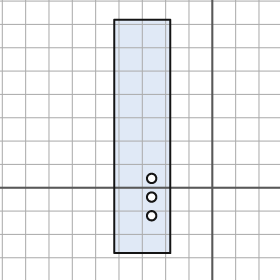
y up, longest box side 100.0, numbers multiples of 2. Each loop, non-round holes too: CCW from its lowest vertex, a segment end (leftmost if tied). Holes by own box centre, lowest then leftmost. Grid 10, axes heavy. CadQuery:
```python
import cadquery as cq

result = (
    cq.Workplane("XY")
    .moveTo(-42.0, -28.0)
    .lineTo(-18.0, -28.0)
    .lineTo(-18.0, 72.0)
    .lineTo(-42.0, 72.0)
    .close()
    .moveTo(-26.0, -12.0)
    .circle(2.0)
    .moveTo(-26.0, -4.0)
    .circle(2.0)
    .moveTo(-26.0, 4.0)
    .circle(2.0)
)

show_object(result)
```